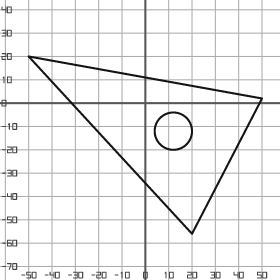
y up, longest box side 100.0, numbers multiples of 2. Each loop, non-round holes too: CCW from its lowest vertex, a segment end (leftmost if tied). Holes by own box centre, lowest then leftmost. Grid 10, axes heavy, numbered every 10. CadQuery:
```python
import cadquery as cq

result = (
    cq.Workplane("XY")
    .moveTo(20.0, -56.0)
    .lineTo(50.0, 2.0)
    .lineTo(-50.0, 20.0)
    .close()
    .moveTo(12.0, -12.0)
    .circle(8.0)
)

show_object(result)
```